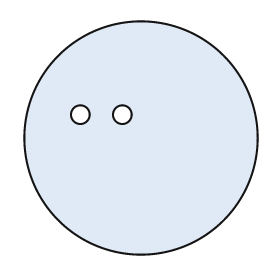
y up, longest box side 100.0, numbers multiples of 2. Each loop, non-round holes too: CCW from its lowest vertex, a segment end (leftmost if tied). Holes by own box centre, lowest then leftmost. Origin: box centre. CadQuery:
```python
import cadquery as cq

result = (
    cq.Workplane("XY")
    .moveTo(0.0, 0.0)
    .circle(50.0)
    .moveTo(-26.0, 10.0)
    .circle(4.0)
    .moveTo(-8.0, 10.0)
    .circle(4.0)
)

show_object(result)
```